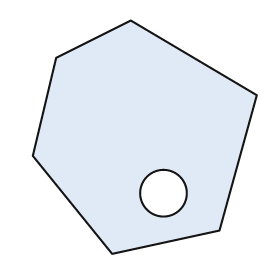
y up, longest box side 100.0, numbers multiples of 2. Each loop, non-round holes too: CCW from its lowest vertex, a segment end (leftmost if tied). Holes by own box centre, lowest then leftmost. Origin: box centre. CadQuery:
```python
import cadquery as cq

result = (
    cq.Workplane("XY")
    .moveTo(-14.0, -50.0)
    .lineTo(32.0, -40.0)
    .lineTo(48.0, 18.0)
    .lineTo(-6.0, 50.0)
    .lineTo(-38.0, 34.0)
    .lineTo(-48.0, -8.0)
    .close()
    .moveTo(8.0, -24.0)
    .circle(10.0)
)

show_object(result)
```